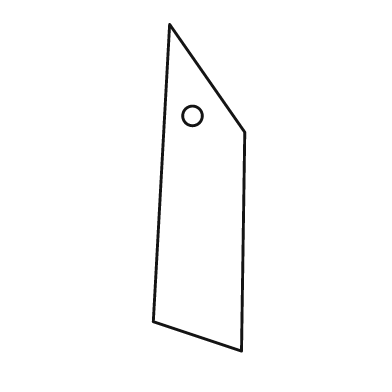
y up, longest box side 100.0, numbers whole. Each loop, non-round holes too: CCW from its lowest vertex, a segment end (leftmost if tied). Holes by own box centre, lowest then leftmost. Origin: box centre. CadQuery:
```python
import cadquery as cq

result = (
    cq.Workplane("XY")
    .moveTo(13.0, -50.0)
    .lineTo(14.0, 17.0)
    .lineTo(-9.0, 50.0)
    .lineTo(-14.0, -41.0)
    .close()
    .moveTo(-2.0, 22.0)
    .circle(3.0)
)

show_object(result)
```